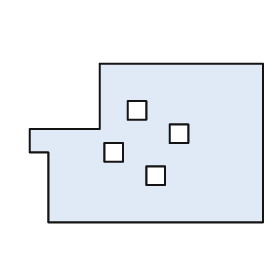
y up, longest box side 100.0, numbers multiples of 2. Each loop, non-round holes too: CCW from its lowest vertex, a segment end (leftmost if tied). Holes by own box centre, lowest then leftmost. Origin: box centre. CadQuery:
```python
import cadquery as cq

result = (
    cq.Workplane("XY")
    .moveTo(-42.0, -34.0)
    .lineTo(50.0, -34.0)
    .lineTo(50.0, 34.0)
    .lineTo(-20.0, 34.0)
    .lineTo(-20.0, 6.0)
    .lineTo(-50.0, 6.0)
    .lineTo(-50.0, -4.0)
    .lineTo(-42.0, -4.0)
    .close()
    .moveTo(0.0, -18.0)
    .lineTo(8.0, -18.0)
    .lineTo(8.0, -10.0)
    .lineTo(0.0, -10.0)
    .close()
    .moveTo(-18.0, -8.0)
    .lineTo(-10.0, -8.0)
    .lineTo(-10.0, 0.0)
    .lineTo(-18.0, 0.0)
    .close()
    .moveTo(10.0, 0.0)
    .lineTo(18.0, 0.0)
    .lineTo(18.0, 8.0)
    .lineTo(10.0, 8.0)
    .close()
    .moveTo(-8.0, 10.0)
    .lineTo(0.0, 10.0)
    .lineTo(0.0, 18.0)
    .lineTo(-8.0, 18.0)
    .close()
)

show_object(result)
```